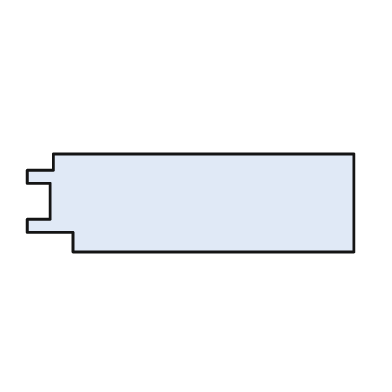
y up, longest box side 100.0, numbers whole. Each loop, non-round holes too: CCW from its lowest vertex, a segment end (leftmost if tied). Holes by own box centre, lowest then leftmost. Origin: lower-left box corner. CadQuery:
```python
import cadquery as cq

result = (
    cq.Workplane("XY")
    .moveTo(14.0, 0.0)
    .lineTo(100.0, 0.0)
    .lineTo(100.0, 30.0)
    .lineTo(8.0, 30.0)
    .lineTo(8.0, 25.0)
    .lineTo(0.0, 25.0)
    .lineTo(0.0, 21.0)
    .lineTo(7.0, 21.0)
    .lineTo(7.0, 10.0)
    .lineTo(0.0, 10.0)
    .lineTo(0.0, 6.0)
    .lineTo(14.0, 6.0)
    .close()
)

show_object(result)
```